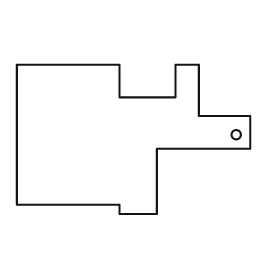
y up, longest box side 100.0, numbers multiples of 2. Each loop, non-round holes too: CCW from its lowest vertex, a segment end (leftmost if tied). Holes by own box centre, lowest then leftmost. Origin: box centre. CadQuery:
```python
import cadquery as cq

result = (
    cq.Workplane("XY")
    .moveTo(-6.0, -32.0)
    .lineTo(10.0, -32.0)
    .lineTo(10.0, -4.0)
    .lineTo(50.0, -4.0)
    .lineTo(50.0, 10.0)
    .lineTo(28.0, 10.0)
    .lineTo(28.0, 32.0)
    .lineTo(18.0, 32.0)
    .lineTo(18.0, 18.0)
    .lineTo(-6.0, 18.0)
    .lineTo(-6.0, 32.0)
    .lineTo(-50.0, 32.0)
    .lineTo(-50.0, -28.0)
    .lineTo(-6.0, -28.0)
    .close()
    .moveTo(44.0, 2.0)
    .circle(2.0)
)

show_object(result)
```